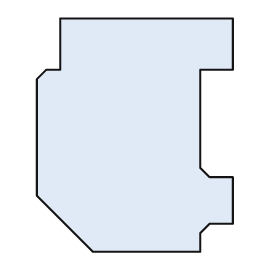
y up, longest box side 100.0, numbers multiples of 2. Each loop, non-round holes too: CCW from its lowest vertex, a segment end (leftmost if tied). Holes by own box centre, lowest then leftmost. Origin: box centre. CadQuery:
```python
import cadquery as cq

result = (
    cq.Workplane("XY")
    .moveTo(-18.0, -50.0)
    .lineTo(28.0, -50.0)
    .lineTo(28.0, -42.0)
    .lineTo(32.0, -38.0)
    .lineTo(42.0, -38.0)
    .lineTo(42.0, -18.0)
    .lineTo(32.0, -18.0)
    .lineTo(28.0, -14.0)
    .lineTo(28.0, 28.0)
    .lineTo(42.0, 28.0)
    .lineTo(42.0, 50.0)
    .lineTo(-32.0, 50.0)
    .lineTo(-32.0, 28.0)
    .lineTo(-38.0, 28.0)
    .lineTo(-42.0, 24.0)
    .lineTo(-42.0, -26.0)
    .close()
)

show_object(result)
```